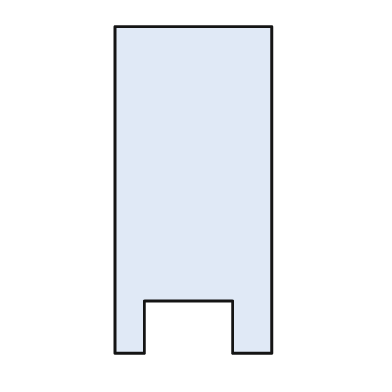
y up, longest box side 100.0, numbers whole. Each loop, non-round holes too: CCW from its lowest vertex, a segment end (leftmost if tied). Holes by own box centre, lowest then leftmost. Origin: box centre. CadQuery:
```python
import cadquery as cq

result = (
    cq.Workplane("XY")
    .moveTo(-24.0, -50.0)
    .lineTo(-15.0, -50.0)
    .lineTo(-15.0, -34.0)
    .lineTo(12.0, -34.0)
    .lineTo(12.0, -50.0)
    .lineTo(24.0, -50.0)
    .lineTo(24.0, 50.0)
    .lineTo(-24.0, 50.0)
    .close()
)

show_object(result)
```